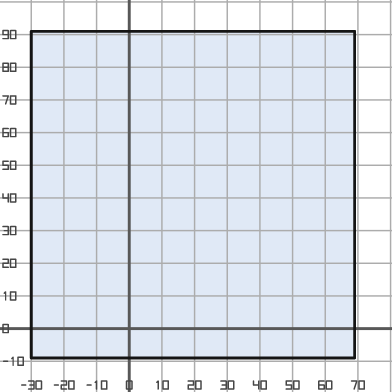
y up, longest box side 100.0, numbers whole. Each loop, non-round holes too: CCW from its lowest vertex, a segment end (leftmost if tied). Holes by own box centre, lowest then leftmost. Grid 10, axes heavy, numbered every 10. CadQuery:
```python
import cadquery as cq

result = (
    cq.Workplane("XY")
    .moveTo(-30.0, -9.0)
    .lineTo(69.0, -9.0)
    .lineTo(69.0, 91.0)
    .lineTo(-30.0, 91.0)
    .close()
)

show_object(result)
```